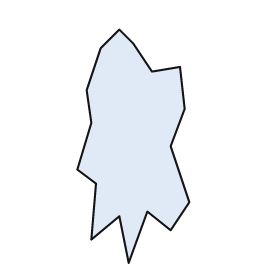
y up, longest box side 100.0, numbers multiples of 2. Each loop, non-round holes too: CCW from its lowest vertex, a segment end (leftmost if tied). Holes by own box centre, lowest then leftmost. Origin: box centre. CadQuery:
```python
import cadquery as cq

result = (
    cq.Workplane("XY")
    .moveTo(-2.0, -50.0)
    .lineTo(6.0, -28.0)
    .lineTo(16.0, -36.0)
    .lineTo(24.0, -24.0)
    .lineTo(16.0, 0.0)
    .lineTo(22.0, 16.0)
    .lineTo(20.0, 34.0)
    .lineTo(8.0, 32.0)
    .lineTo(0.0, 44.0)
    .lineTo(-6.0, 50.0)
    .lineTo(-14.0, 42.0)
    .lineTo(-20.0, 24.0)
    .lineTo(-18.0, 10.0)
    .lineTo(-24.0, -10.0)
    .lineTo(-16.0, -16.0)
    .lineTo(-18.0, -40.0)
    .lineTo(-6.0, -30.0)
    .close()
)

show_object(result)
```